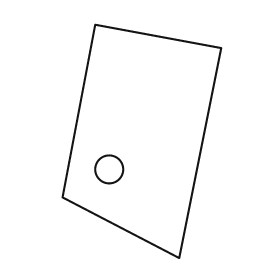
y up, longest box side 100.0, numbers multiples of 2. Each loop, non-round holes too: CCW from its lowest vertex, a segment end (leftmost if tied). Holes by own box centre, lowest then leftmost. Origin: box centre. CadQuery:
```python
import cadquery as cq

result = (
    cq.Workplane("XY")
    .moveTo(16.0, -50.0)
    .lineTo(34.0, 40.0)
    .lineTo(-20.0, 50.0)
    .lineTo(-34.0, -24.0)
    .close()
    .moveTo(-14.0, -12.0)
    .circle(6.0)
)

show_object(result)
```